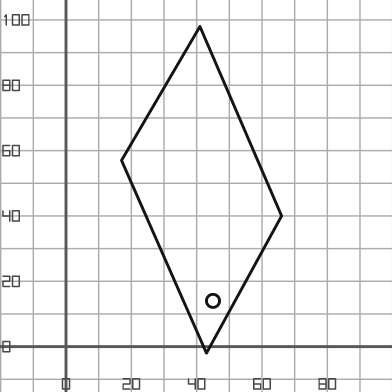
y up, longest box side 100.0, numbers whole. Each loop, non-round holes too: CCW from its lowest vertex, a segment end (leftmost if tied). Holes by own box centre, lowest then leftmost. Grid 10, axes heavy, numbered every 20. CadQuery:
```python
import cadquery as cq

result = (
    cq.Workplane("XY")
    .moveTo(43.0, -2.0)
    .lineTo(66.0, 40.0)
    .lineTo(41.0, 98.0)
    .lineTo(17.0, 57.0)
    .close()
    .moveTo(45.0, 14.0)
    .circle(2.0)
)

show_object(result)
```